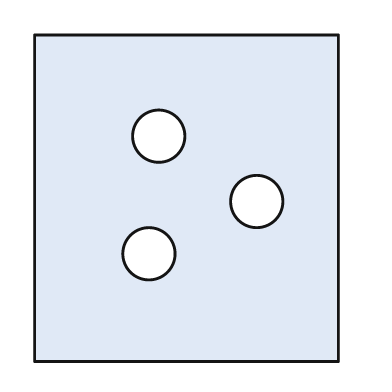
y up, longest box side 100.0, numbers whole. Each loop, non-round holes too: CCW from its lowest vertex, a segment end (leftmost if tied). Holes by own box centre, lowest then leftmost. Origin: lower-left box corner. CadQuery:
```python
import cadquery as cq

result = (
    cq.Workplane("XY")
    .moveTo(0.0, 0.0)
    .lineTo(93.0, 0.0)
    .lineTo(93.0, 100.0)
    .lineTo(0.0, 100.0)
    .close()
    .moveTo(35.0, 33.0)
    .circle(8.0)
    .moveTo(68.0, 49.0)
    .circle(8.0)
    .moveTo(38.0, 69.0)
    .circle(8.0)
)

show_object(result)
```